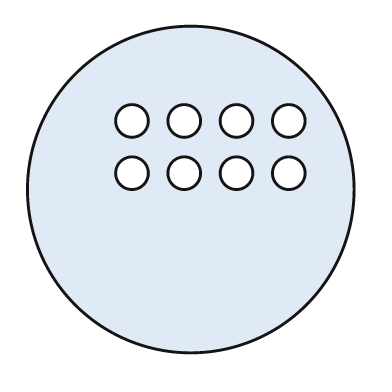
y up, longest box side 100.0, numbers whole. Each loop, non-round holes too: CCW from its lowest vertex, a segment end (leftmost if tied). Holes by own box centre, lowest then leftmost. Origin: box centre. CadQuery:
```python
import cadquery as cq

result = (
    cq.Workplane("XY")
    .moveTo(0.0, 0.0)
    .circle(50.0)
    .moveTo(-18.0, 5.0)
    .circle(5.0)
    .moveTo(-2.0, 5.0)
    .circle(5.0)
    .moveTo(14.0, 5.0)
    .circle(5.0)
    .moveTo(30.0, 5.0)
    .circle(5.0)
    .moveTo(-18.0, 21.0)
    .circle(5.0)
    .moveTo(-2.0, 21.0)
    .circle(5.0)
    .moveTo(14.0, 21.0)
    .circle(5.0)
    .moveTo(30.0, 21.0)
    .circle(5.0)
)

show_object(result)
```